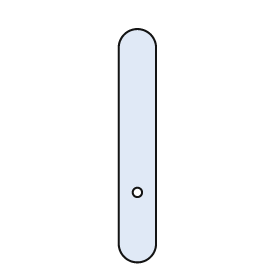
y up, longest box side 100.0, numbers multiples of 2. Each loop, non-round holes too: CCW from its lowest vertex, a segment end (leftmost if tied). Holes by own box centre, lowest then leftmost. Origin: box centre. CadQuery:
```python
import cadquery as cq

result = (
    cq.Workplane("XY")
    .moveTo(-8.0, -42.0)
    .threePointArc((0.0, -50.0), (8.0, -42.0))
    .lineTo(8.0, 42.0)
    .threePointArc((0.0, 50.0), (-8.0, 42.0))
    .close()
    .moveTo(0.0, -20.0)
    .circle(2.0)
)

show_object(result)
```